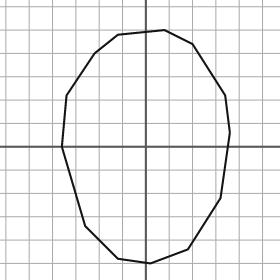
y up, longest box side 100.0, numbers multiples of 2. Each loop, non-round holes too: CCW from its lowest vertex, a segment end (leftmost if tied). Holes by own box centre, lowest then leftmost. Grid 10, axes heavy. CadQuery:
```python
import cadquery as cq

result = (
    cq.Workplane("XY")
    .moveTo(2.0, -50.0)
    .lineTo(18.0, -44.0)
    .lineTo(32.0, -22.0)
    .lineTo(36.0, 6.0)
    .lineTo(34.0, 22.0)
    .lineTo(20.0, 44.0)
    .lineTo(8.0, 50.0)
    .lineTo(-12.0, 48.0)
    .lineTo(-22.0, 40.0)
    .lineTo(-34.0, 22.0)
    .lineTo(-36.0, 0.0)
    .lineTo(-26.0, -34.0)
    .lineTo(-12.0, -48.0)
    .close()
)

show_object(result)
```